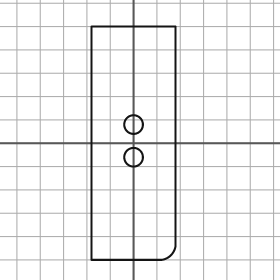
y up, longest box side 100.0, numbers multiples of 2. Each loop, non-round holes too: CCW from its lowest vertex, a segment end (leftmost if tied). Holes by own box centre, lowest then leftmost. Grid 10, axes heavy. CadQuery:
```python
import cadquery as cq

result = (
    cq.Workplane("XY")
    .moveTo(-18.0, -50.0)
    .lineTo(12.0, -50.0)
    .threePointArc((16.0, -48.0), (18.0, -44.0))
    .lineTo(18.0, 50.0)
    .lineTo(-18.0, 50.0)
    .close()
    .moveTo(0.0, -6.0)
    .circle(4.0)
    .moveTo(0.0, 8.0)
    .circle(4.0)
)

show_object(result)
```